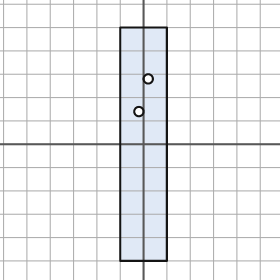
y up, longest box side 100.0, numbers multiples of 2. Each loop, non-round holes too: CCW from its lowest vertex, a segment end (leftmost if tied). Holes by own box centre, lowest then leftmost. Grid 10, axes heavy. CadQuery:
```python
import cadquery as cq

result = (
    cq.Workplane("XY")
    .moveTo(-10.0, -50.0)
    .lineTo(10.0, -50.0)
    .lineTo(10.0, 50.0)
    .lineTo(-10.0, 50.0)
    .close()
    .moveTo(-2.0, 14.0)
    .circle(2.0)
    .moveTo(2.0, 28.0)
    .circle(2.0)
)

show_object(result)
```